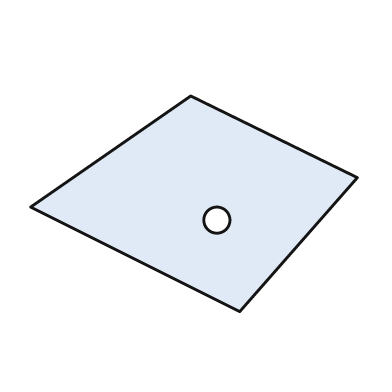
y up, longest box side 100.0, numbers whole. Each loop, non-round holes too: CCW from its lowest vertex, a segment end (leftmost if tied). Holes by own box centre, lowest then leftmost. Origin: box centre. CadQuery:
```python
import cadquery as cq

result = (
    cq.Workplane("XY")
    .moveTo(14.0, -33.0)
    .lineTo(50.0, 8.0)
    .lineTo(-1.0, 33.0)
    .lineTo(-50.0, -1.0)
    .close()
    .moveTo(7.0, -5.0)
    .circle(4.0)
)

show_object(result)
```